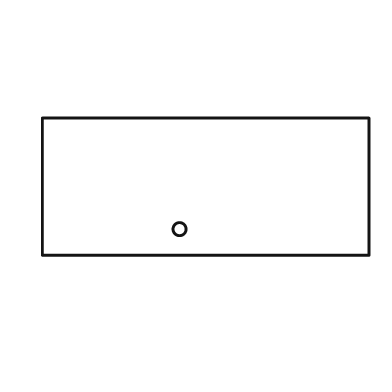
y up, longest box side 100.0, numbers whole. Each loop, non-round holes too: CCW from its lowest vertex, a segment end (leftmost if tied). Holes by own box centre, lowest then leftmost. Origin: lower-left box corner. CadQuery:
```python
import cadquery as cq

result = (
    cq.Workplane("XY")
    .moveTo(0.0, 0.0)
    .lineTo(100.0, 0.0)
    .lineTo(100.0, 42.0)
    .lineTo(0.0, 42.0)
    .close()
    .moveTo(42.0, 8.0)
    .circle(2.0)
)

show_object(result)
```